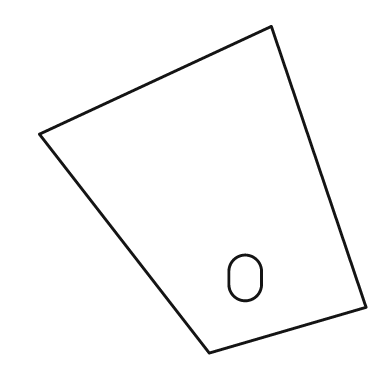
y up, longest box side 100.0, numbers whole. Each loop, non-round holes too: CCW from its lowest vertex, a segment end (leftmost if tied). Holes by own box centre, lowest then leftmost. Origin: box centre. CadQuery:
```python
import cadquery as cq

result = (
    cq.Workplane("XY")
    .moveTo(2.0, -50.0)
    .lineTo(50.0, -36.0)
    .lineTo(21.0, 50.0)
    .lineTo(-50.0, 17.0)
    .close()
    .moveTo(8.0, -29.0)
    .threePointArc((13.0, -34.0), (18.0, -29.0))
    .lineTo(18.0, -25.0)
    .threePointArc((13.0, -20.0), (8.0, -25.0))
    .close()
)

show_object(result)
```